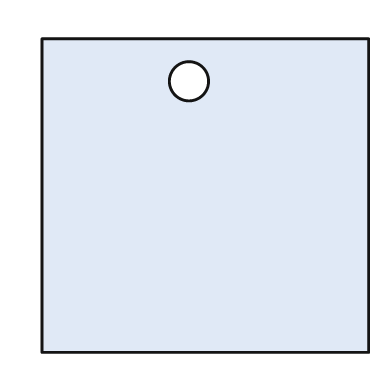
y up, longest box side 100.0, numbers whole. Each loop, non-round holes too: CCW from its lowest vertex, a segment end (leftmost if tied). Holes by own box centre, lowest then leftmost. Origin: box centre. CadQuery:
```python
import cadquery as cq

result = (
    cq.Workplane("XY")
    .moveTo(-50.0, -48.0)
    .lineTo(50.0, -48.0)
    .lineTo(50.0, 48.0)
    .lineTo(-50.0, 48.0)
    .close()
    .moveTo(-5.0, 35.0)
    .circle(6.0)
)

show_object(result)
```